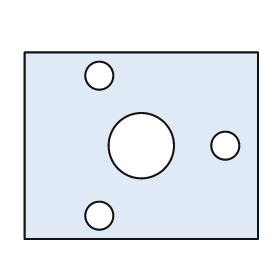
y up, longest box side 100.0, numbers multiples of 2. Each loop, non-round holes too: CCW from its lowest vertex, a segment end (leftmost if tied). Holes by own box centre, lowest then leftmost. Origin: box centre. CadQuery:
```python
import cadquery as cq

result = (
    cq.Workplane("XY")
    .moveTo(-50.0, -40.0)
    .lineTo(50.0, -40.0)
    .lineTo(50.0, 40.0)
    .lineTo(-50.0, 40.0)
    .close()
    .moveTo(-18.0, -30.0)
    .circle(6.0)
    .moveTo(0.0, 0.0)
    .circle(14.0)
    .moveTo(36.0, 0.0)
    .circle(6.0)
    .moveTo(-18.0, 30.0)
    .circle(6.0)
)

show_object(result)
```